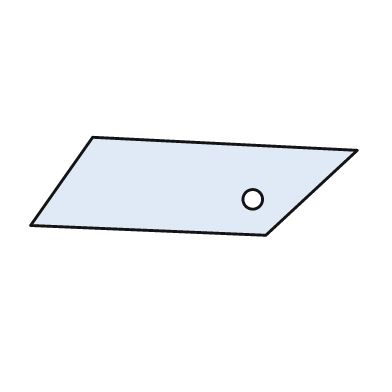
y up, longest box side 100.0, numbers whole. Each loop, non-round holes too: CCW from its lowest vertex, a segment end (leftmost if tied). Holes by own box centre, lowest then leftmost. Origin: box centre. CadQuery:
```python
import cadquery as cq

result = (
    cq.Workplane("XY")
    .moveTo(22.0, -15.0)
    .lineTo(50.0, 11.0)
    .lineTo(-31.0, 15.0)
    .lineTo(-50.0, -12.0)
    .close()
    .moveTo(18.0, -4.0)
    .circle(3.0)
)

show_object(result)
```